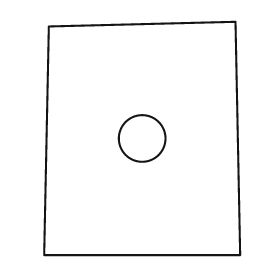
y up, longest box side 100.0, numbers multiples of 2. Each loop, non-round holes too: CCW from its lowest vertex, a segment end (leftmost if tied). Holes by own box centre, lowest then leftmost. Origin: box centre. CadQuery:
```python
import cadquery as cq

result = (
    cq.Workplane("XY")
    .moveTo(-42.0, -50.0)
    .lineTo(42.0, -50.0)
    .lineTo(40.0, 50.0)
    .lineTo(-40.0, 48.0)
    .close()
    .moveTo(0.0, 0.0)
    .circle(10.0)
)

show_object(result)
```